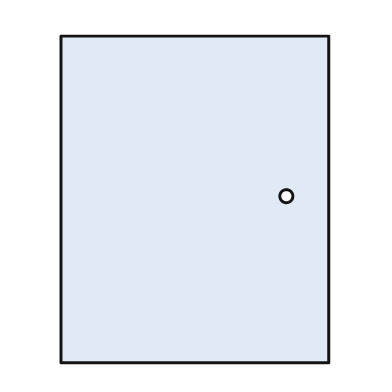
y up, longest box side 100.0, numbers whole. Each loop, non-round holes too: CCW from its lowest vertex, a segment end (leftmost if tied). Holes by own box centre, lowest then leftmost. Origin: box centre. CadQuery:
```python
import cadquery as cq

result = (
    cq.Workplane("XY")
    .moveTo(-41.0, -50.0)
    .lineTo(41.0, -50.0)
    .lineTo(41.0, 50.0)
    .lineTo(-41.0, 50.0)
    .close()
    .moveTo(28.0, 1.0)
    .circle(2.0)
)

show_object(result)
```